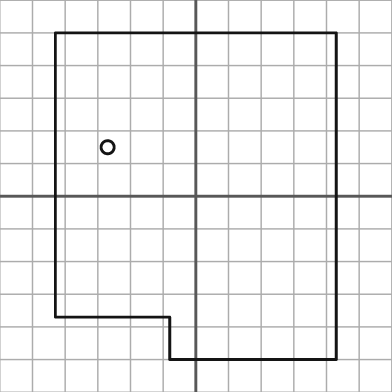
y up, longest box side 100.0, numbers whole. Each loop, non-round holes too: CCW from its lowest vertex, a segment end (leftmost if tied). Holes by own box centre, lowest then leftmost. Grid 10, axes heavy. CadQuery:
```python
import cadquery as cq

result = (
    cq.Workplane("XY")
    .moveTo(-8.0, -50.0)
    .lineTo(43.0, -50.0)
    .lineTo(43.0, 50.0)
    .lineTo(-43.0, 50.0)
    .lineTo(-43.0, -37.0)
    .lineTo(-8.0, -37.0)
    .close()
    .moveTo(-27.0, 15.0)
    .circle(2.0)
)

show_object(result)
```